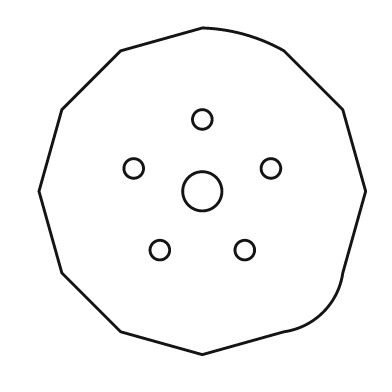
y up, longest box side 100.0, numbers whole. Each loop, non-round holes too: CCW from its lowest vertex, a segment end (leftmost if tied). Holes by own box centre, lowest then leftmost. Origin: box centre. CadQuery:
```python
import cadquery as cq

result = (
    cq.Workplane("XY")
    .moveTo(0.0, -50.0)
    .lineTo(25.0, -43.0)
    .threePointArc((37.0, -37.0), (43.0, -25.0))
    .lineTo(50.0, 0.0)
    .lineTo(43.0, 25.0)
    .lineTo(25.0, 43.0)
    .threePointArc((13.0, 48.0), (0.0, 50.0))
    .lineTo(-25.0, 43.0)
    .lineTo(-43.0, 25.0)
    .lineTo(-50.0, 0.0)
    .lineTo(-43.0, -25.0)
    .lineTo(-25.0, -43.0)
    .close()
    .moveTo(-13.0, -18.0)
    .circle(3.0)
    .moveTo(13.0, -18.0)
    .circle(3.0)
    .moveTo(0.0, 0.0)
    .circle(6.0)
    .moveTo(-21.0, 7.0)
    .circle(3.0)
    .moveTo(21.0, 7.0)
    .circle(3.0)
    .moveTo(0.0, 22.0)
    .circle(3.0)
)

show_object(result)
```